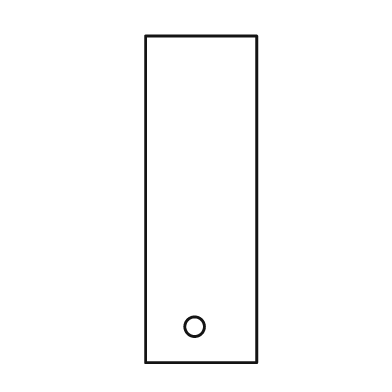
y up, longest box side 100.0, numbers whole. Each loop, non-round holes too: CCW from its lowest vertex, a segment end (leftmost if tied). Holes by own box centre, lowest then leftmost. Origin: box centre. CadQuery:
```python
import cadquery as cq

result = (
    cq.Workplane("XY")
    .moveTo(-17.0, -50.0)
    .lineTo(17.0, -50.0)
    .lineTo(17.0, 50.0)
    .lineTo(-17.0, 50.0)
    .close()
    .moveTo(-2.0, -39.0)
    .circle(3.0)
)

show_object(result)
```